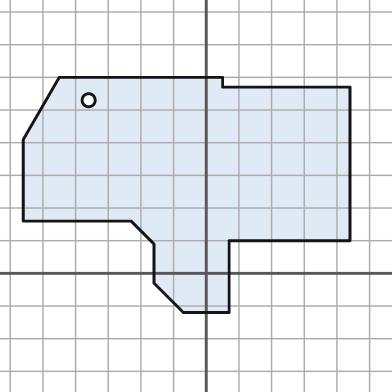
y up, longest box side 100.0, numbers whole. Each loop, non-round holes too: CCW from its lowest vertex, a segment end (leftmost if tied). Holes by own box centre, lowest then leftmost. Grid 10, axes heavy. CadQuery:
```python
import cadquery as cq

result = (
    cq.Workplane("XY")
    .moveTo(-7.0, -12.0)
    .lineTo(7.0, -12.0)
    .lineTo(7.0, 10.0)
    .lineTo(44.0, 10.0)
    .lineTo(44.0, 57.0)
    .lineTo(5.0, 57.0)
    .lineTo(5.0, 60.0)
    .lineTo(-45.0, 60.0)
    .lineTo(-56.0, 41.0)
    .lineTo(-56.0, 16.0)
    .lineTo(-23.0, 16.0)
    .lineTo(-16.0, 9.0)
    .lineTo(-16.0, -3.0)
    .close()
    .moveTo(-36.0, 53.0)
    .circle(2.0)
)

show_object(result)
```